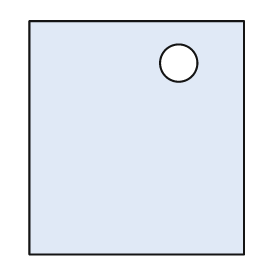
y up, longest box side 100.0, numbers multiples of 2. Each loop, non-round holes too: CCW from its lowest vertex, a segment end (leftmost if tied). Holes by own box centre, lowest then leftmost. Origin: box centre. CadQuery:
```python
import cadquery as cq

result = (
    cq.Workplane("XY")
    .moveTo(-46.0, -50.0)
    .lineTo(46.0, -50.0)
    .lineTo(46.0, 50.0)
    .lineTo(-46.0, 50.0)
    .close()
    .moveTo(18.0, 32.0)
    .circle(8.0)
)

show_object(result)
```